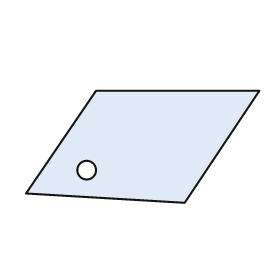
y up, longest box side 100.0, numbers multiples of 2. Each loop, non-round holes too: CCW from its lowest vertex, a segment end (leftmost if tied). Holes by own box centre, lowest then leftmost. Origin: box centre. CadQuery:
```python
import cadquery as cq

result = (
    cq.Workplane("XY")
    .moveTo(18.0, -24.0)
    .lineTo(50.0, 24.0)
    .lineTo(-20.0, 24.0)
    .lineTo(-50.0, -20.0)
    .close()
    .moveTo(-24.0, -10.0)
    .circle(4.0)
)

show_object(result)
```